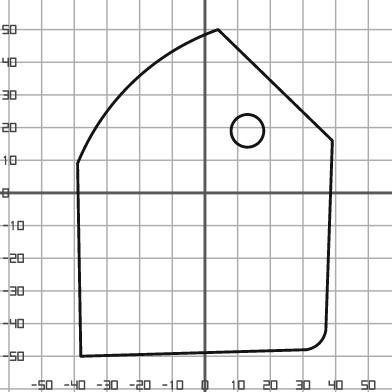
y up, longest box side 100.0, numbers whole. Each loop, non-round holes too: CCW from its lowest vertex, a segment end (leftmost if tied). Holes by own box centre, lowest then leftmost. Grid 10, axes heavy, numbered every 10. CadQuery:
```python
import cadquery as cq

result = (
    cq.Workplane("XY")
    .moveTo(-38.0, -50.0)
    .lineTo(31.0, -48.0)
    .threePointArc((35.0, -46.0), (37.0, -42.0))
    .lineTo(39.0, 16.0)
    .lineTo(4.0, 50.0)
    .threePointArc((-22.0, 34.0), (-39.0, 9.0))
    .close()
    .moveTo(13.0, 19.0)
    .circle(5.0)
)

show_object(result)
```